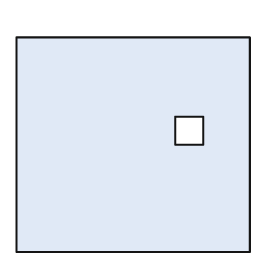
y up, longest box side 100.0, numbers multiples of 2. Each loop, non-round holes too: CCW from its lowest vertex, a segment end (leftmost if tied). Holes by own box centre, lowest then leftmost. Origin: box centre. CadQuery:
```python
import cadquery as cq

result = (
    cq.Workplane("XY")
    .moveTo(-50.0, -46.0)
    .lineTo(50.0, -46.0)
    .lineTo(50.0, 46.0)
    .lineTo(-50.0, 46.0)
    .close()
    .moveTo(18.0, 0.0)
    .lineTo(30.0, 0.0)
    .lineTo(30.0, 12.0)
    .lineTo(18.0, 12.0)
    .close()
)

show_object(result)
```